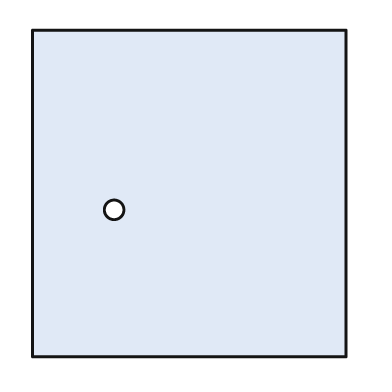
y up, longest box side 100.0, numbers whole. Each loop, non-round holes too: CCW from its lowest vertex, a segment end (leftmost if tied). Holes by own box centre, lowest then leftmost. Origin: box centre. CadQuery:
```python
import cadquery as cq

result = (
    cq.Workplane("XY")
    .moveTo(-48.0, -50.0)
    .lineTo(48.0, -50.0)
    .lineTo(48.0, 50.0)
    .lineTo(-48.0, 50.0)
    .close()
    .moveTo(-23.0, -5.0)
    .circle(3.0)
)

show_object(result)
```